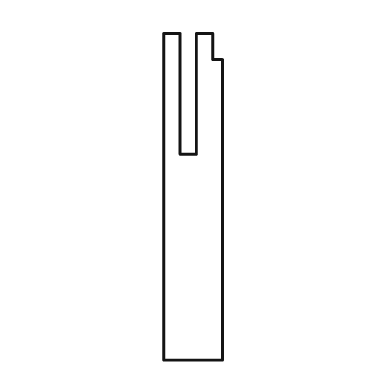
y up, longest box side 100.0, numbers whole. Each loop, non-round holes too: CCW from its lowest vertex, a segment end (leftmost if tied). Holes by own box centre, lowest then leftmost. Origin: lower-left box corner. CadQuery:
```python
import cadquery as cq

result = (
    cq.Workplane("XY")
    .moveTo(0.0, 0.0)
    .lineTo(18.0, 0.0)
    .lineTo(18.0, 92.0)
    .lineTo(15.0, 92.0)
    .lineTo(15.0, 100.0)
    .lineTo(10.0, 100.0)
    .lineTo(10.0, 63.0)
    .lineTo(5.0, 63.0)
    .lineTo(5.0, 100.0)
    .lineTo(0.0, 100.0)
    .close()
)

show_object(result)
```